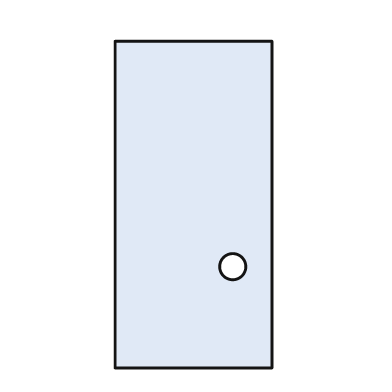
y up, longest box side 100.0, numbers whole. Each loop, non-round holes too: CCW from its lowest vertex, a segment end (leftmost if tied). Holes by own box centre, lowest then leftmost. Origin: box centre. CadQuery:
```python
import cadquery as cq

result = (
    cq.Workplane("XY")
    .moveTo(-24.0, -50.0)
    .lineTo(24.0, -50.0)
    .lineTo(24.0, 50.0)
    .lineTo(-24.0, 50.0)
    .close()
    .moveTo(12.0, -19.0)
    .circle(4.0)
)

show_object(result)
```